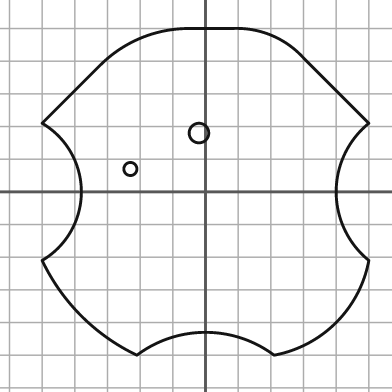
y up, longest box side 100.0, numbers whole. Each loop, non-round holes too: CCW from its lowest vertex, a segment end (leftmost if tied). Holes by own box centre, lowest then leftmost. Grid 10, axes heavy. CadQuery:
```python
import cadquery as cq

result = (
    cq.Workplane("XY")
    .moveTo(-21.0, -50.0)
    .threePointArc((0.0, -43.0), (21.0, -50.0))
    .threePointArc((40.0, -40.0), (50.0, -21.0))
    .threePointArc((40.0, 0.0), (50.0, 21.0))
    .lineTo(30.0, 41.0)
    .threePointArc((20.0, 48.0), (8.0, 50.0))
    .lineTo(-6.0, 50.0)
    .threePointArc((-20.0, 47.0), (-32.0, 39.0))
    .lineTo(-50.0, 21.0)
    .threePointArc((-38.0, 0.0), (-50.0, -21.0))
    .threePointArc((-38.0, -38.0), (-21.0, -50.0))
    .close()
    .moveTo(-23.0, 7.0)
    .circle(2.0)
    .moveTo(-2.0, 18.0)
    .circle(3.0)
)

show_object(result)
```